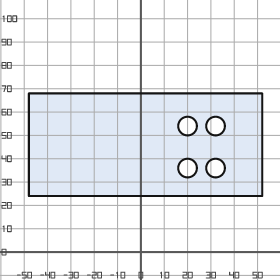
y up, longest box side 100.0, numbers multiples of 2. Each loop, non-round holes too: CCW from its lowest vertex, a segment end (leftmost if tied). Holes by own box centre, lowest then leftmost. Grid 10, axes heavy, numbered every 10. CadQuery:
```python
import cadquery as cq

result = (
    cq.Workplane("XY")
    .moveTo(-48.0, 24.0)
    .lineTo(52.0, 24.0)
    .lineTo(52.0, 68.0)
    .lineTo(-48.0, 68.0)
    .close()
    .moveTo(20.0, 36.0)
    .circle(4.0)
    .moveTo(32.0, 36.0)
    .circle(4.0)
    .moveTo(20.0, 54.0)
    .circle(4.0)
    .moveTo(32.0, 54.0)
    .circle(4.0)
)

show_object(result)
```